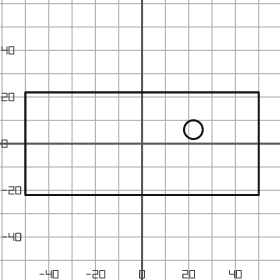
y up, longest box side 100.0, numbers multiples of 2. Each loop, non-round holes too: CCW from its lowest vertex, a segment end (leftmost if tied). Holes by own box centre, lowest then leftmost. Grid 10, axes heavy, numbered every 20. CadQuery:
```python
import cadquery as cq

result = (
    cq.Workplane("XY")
    .moveTo(-50.0, -22.0)
    .lineTo(50.0, -22.0)
    .lineTo(50.0, 22.0)
    .lineTo(-50.0, 22.0)
    .close()
    .moveTo(22.0, 6.0)
    .circle(4.0)
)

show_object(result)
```